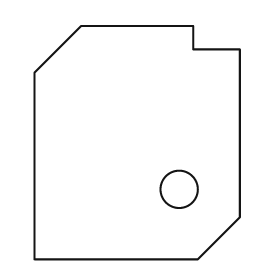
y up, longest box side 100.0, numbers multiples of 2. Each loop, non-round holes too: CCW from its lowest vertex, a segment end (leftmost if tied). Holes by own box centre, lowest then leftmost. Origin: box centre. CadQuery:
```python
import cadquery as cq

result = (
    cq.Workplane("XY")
    .moveTo(-44.0, -50.0)
    .lineTo(26.0, -50.0)
    .lineTo(44.0, -32.0)
    .lineTo(44.0, 40.0)
    .lineTo(24.0, 40.0)
    .lineTo(24.0, 50.0)
    .lineTo(-24.0, 50.0)
    .lineTo(-44.0, 30.0)
    .close()
    .moveTo(18.0, -20.0)
    .circle(8.0)
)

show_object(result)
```